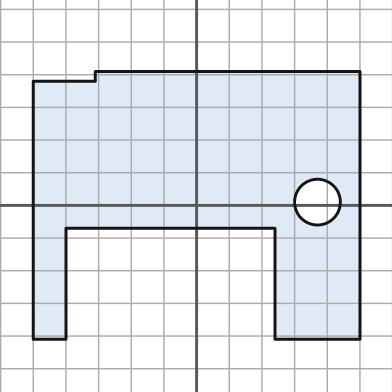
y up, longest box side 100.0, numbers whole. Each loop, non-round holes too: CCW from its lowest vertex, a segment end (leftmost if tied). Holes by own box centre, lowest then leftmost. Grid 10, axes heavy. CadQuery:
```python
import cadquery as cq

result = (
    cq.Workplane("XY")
    .moveTo(-50.0, -41.0)
    .lineTo(-40.0, -41.0)
    .lineTo(-40.0, -7.0)
    .lineTo(24.0, -7.0)
    .lineTo(24.0, -41.0)
    .lineTo(50.0, -41.0)
    .lineTo(50.0, 41.0)
    .lineTo(-31.0, 41.0)
    .lineTo(-31.0, 38.0)
    .lineTo(-50.0, 38.0)
    .close()
    .moveTo(37.0, 1.0)
    .circle(7.0)
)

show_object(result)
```